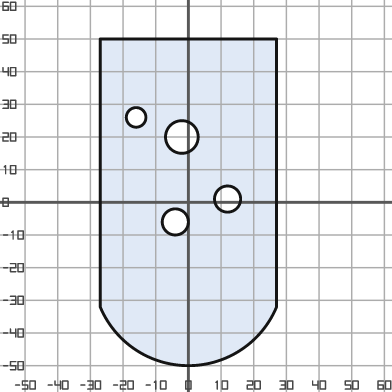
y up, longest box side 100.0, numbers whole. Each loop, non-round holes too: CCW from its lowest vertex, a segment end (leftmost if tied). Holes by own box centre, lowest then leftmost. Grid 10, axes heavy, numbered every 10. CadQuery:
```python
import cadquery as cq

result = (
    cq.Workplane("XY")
    .moveTo(-27.0, -32.0)
    .threePointArc((0.0, -50.0), (27.0, -32.0))
    .lineTo(27.0, 50.0)
    .lineTo(-27.0, 50.0)
    .close()
    .moveTo(-4.0, -6.0)
    .circle(4.0)
    .moveTo(12.0, 1.0)
    .circle(4.0)
    .moveTo(-2.0, 20.0)
    .circle(5.0)
    .moveTo(-16.0, 26.0)
    .circle(3.0)
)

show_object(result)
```